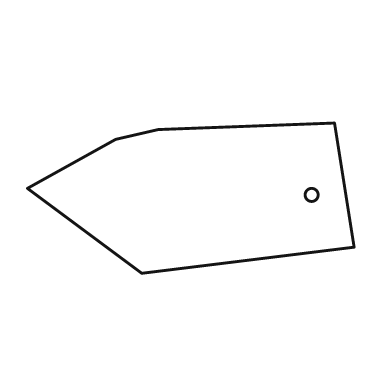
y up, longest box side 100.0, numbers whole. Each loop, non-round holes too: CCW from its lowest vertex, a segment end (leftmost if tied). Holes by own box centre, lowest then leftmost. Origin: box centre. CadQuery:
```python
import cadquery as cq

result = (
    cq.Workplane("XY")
    .moveTo(-15.0, -23.0)
    .lineTo(50.0, -15.0)
    .lineTo(44.0, 23.0)
    .lineTo(-10.0, 21.0)
    .lineTo(-23.0, 18.0)
    .lineTo(-50.0, 3.0)
    .close()
    .moveTo(37.0, 1.0)
    .circle(2.0)
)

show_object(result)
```